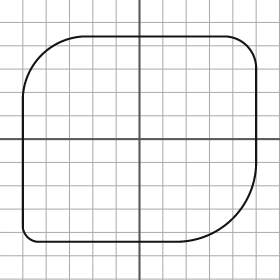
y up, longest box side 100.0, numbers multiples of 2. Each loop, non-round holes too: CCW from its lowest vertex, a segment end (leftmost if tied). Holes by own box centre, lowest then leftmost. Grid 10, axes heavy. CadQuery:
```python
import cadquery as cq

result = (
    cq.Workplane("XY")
    .moveTo(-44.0, -44.0)
    .lineTo(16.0, -44.0)
    .threePointArc((40.0, -34.0), (50.0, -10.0))
    .lineTo(50.0, 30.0)
    .threePointArc((46.0, 40.0), (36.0, 44.0))
    .lineTo(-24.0, 44.0)
    .threePointArc((-42.0, 36.0), (-50.0, 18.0))
    .lineTo(-50.0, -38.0)
    .threePointArc((-48.0, -42.0), (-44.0, -44.0))
    .close()
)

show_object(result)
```